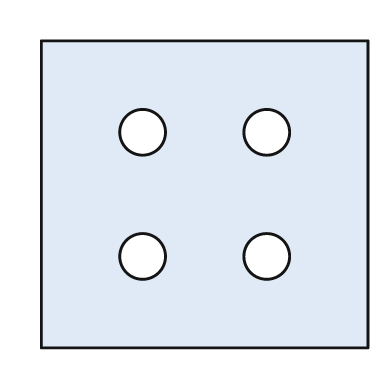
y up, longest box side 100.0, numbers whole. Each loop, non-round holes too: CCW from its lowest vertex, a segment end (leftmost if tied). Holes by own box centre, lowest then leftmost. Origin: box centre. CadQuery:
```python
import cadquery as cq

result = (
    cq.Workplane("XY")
    .moveTo(-50.0, -47.0)
    .lineTo(50.0, -47.0)
    .lineTo(50.0, 47.0)
    .lineTo(-50.0, 47.0)
    .close()
    .moveTo(-19.0, -19.0)
    .circle(7.0)
    .moveTo(19.0, -19.0)
    .circle(7.0)
    .moveTo(-19.0, 19.0)
    .circle(7.0)
    .moveTo(19.0, 19.0)
    .circle(7.0)
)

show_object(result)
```